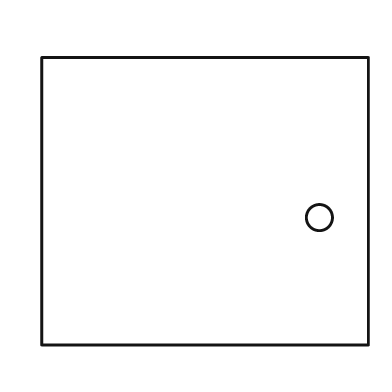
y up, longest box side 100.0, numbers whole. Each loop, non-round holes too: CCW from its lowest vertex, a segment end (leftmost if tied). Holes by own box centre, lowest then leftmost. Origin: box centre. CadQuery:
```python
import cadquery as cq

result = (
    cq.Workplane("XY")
    .moveTo(-50.0, -44.0)
    .lineTo(50.0, -44.0)
    .lineTo(50.0, 44.0)
    .lineTo(-50.0, 44.0)
    .close()
    .moveTo(35.0, -5.0)
    .circle(4.0)
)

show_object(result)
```